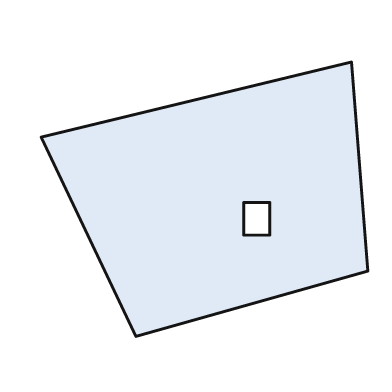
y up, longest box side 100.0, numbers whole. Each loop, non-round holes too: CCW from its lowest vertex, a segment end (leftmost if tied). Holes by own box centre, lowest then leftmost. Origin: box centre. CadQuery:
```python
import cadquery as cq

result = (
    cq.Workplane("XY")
    .moveTo(-21.0, -42.0)
    .lineTo(50.0, -22.0)
    .lineTo(45.0, 42.0)
    .lineTo(-50.0, 19.0)
    .close()
    .moveTo(12.0, -11.0)
    .lineTo(20.0, -11.0)
    .lineTo(20.0, -1.0)
    .lineTo(12.0, -1.0)
    .close()
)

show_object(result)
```